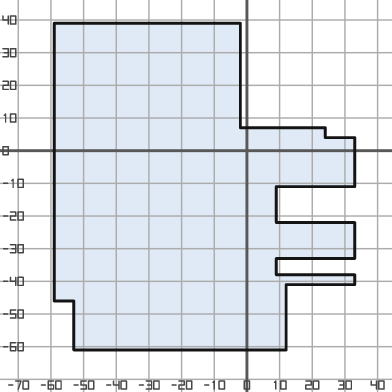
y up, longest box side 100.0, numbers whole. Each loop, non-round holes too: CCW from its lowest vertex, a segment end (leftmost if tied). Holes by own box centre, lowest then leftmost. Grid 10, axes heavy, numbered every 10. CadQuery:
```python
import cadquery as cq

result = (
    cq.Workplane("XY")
    .moveTo(-53.0, -61.0)
    .lineTo(12.0, -61.0)
    .lineTo(12.0, -41.0)
    .lineTo(33.0, -41.0)
    .lineTo(33.0, -38.0)
    .lineTo(9.0, -38.0)
    .lineTo(9.0, -33.0)
    .lineTo(33.0, -33.0)
    .lineTo(33.0, -22.0)
    .lineTo(9.0, -22.0)
    .lineTo(9.0, -11.0)
    .lineTo(33.0, -11.0)
    .lineTo(33.0, 4.0)
    .lineTo(24.0, 4.0)
    .lineTo(24.0, 7.0)
    .lineTo(-2.0, 7.0)
    .lineTo(-2.0, 39.0)
    .lineTo(-59.0, 39.0)
    .lineTo(-59.0, -46.0)
    .lineTo(-53.0, -46.0)
    .close()
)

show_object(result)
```